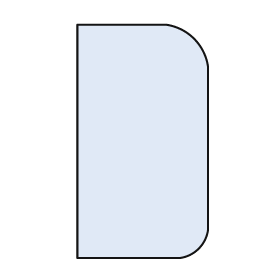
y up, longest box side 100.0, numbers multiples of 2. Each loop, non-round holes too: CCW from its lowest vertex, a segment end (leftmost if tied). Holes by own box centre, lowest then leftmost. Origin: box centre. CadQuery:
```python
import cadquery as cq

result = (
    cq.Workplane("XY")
    .moveTo(-28.0, -50.0)
    .lineTo(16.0, -50.0)
    .threePointArc((24.0, -46.0), (28.0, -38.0))
    .lineTo(28.0, 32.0)
    .threePointArc((22.0, 44.0), (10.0, 50.0))
    .lineTo(-28.0, 50.0)
    .close()
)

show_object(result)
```